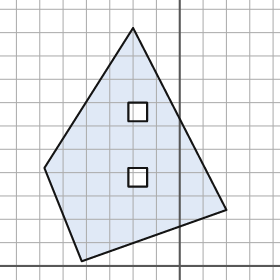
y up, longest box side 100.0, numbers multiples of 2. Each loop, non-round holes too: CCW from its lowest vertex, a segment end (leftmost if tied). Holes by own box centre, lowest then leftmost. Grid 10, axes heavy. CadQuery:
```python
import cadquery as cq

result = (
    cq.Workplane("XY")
    .moveTo(-42.0, 2.0)
    .lineTo(20.0, 24.0)
    .lineTo(-20.0, 102.0)
    .lineTo(-58.0, 42.0)
    .close()
    .moveTo(-22.0, 34.0)
    .lineTo(-14.0, 34.0)
    .lineTo(-14.0, 42.0)
    .lineTo(-22.0, 42.0)
    .close()
    .moveTo(-22.0, 62.0)
    .lineTo(-14.0, 62.0)
    .lineTo(-14.0, 70.0)
    .lineTo(-22.0, 70.0)
    .close()
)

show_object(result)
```